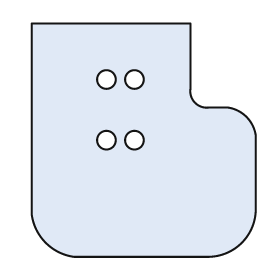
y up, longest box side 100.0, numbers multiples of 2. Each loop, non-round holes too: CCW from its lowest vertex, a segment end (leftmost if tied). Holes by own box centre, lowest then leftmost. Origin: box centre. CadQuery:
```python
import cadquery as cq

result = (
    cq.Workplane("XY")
    .moveTo(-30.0, -50.0)
    .lineTo(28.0, -50.0)
    .threePointArc((42.0, -44.0), (48.0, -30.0))
    .lineTo(48.0, 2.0)
    .threePointArc((44.0, 10.0), (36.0, 14.0))
    .lineTo(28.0, 14.0)
    .threePointArc((22.0, 16.0), (20.0, 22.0))
    .lineTo(20.0, 50.0)
    .lineTo(-48.0, 50.0)
    .lineTo(-48.0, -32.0)
    .threePointArc((-42.0, -44.0), (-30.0, -50.0))
    .close()
    .moveTo(-16.0, 0.0)
    .circle(4.0)
    .moveTo(-4.0, 0.0)
    .circle(4.0)
    .moveTo(-16.0, 26.0)
    .circle(4.0)
    .moveTo(-4.0, 26.0)
    .circle(4.0)
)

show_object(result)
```